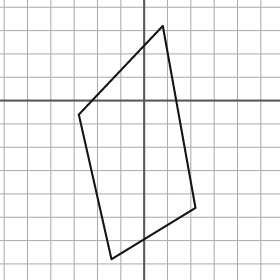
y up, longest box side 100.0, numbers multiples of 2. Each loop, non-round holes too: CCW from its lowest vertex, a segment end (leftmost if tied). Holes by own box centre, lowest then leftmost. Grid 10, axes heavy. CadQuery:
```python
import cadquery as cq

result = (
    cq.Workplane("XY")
    .moveTo(-14.0, -68.0)
    .lineTo(22.0, -46.0)
    .lineTo(8.0, 32.0)
    .lineTo(-28.0, -6.0)
    .close()
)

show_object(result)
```